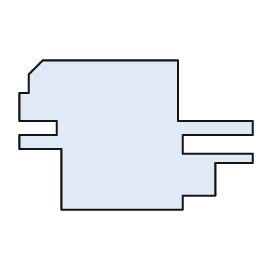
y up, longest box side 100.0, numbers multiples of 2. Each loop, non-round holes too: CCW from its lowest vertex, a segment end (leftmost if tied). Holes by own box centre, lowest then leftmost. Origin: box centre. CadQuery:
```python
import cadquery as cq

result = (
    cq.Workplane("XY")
    .moveTo(-32.0, -32.0)
    .lineTo(20.0, -32.0)
    .lineTo(20.0, -26.0)
    .lineTo(34.0, -26.0)
    .lineTo(34.0, -12.0)
    .lineTo(50.0, -12.0)
    .lineTo(50.0, -8.0)
    .lineTo(20.0, -8.0)
    .lineTo(20.0, 0.0)
    .lineTo(50.0, 0.0)
    .lineTo(50.0, 6.0)
    .lineTo(18.0, 6.0)
    .lineTo(18.0, 32.0)
    .lineTo(-40.0, 32.0)
    .lineTo(-46.0, 26.0)
    .lineTo(-46.0, 18.0)
    .lineTo(-50.0, 18.0)
    .lineTo(-50.0, 6.0)
    .lineTo(-34.0, 6.0)
    .lineTo(-34.0, 0.0)
    .lineTo(-50.0, 0.0)
    .lineTo(-50.0, -6.0)
    .lineTo(-32.0, -6.0)
    .close()
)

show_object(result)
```